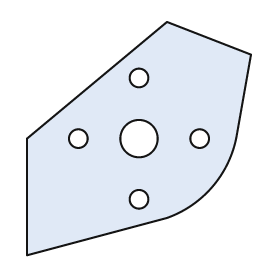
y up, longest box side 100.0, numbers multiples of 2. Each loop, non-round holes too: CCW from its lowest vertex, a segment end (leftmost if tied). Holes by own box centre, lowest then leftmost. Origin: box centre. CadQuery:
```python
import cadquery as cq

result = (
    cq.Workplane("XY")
    .moveTo(-48.0, -50.0)
    .lineTo(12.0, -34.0)
    .threePointArc((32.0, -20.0), (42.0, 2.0))
    .lineTo(48.0, 36.0)
    .lineTo(12.0, 50.0)
    .lineTo(-48.0, 0.0)
    .close()
    .moveTo(0.0, -26.0)
    .circle(4.0)
    .moveTo(-26.0, 0.0)
    .circle(4.0)
    .moveTo(0.0, 0.0)
    .circle(8.0)
    .moveTo(26.0, 0.0)
    .circle(4.0)
    .moveTo(0.0, 26.0)
    .circle(4.0)
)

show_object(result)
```